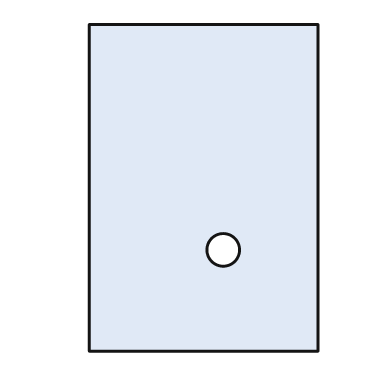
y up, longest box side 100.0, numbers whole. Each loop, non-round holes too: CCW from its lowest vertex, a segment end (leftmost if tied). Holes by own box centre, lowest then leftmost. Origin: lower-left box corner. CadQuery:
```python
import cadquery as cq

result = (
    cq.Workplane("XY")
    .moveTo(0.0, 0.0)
    .lineTo(70.0, 0.0)
    .lineTo(70.0, 100.0)
    .lineTo(0.0, 100.0)
    .close()
    .moveTo(41.0, 31.0)
    .circle(5.0)
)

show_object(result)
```